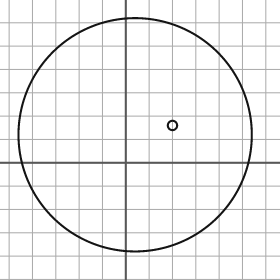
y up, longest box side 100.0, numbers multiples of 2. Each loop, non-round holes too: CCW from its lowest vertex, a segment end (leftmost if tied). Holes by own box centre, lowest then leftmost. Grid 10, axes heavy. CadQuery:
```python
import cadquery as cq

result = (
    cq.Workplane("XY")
    .moveTo(4.0, 12.0)
    .circle(50.0)
    .moveTo(20.0, 16.0)
    .circle(2.0)
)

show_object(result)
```